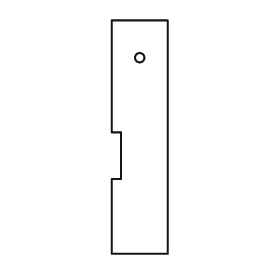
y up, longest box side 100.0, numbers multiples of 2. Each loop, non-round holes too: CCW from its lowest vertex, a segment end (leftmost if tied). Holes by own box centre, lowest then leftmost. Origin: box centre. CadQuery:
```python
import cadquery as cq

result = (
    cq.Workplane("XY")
    .moveTo(-12.0, -50.0)
    .lineTo(12.0, -50.0)
    .lineTo(12.0, 50.0)
    .lineTo(-12.0, 50.0)
    .lineTo(-12.0, 2.0)
    .lineTo(-8.0, 2.0)
    .lineTo(-8.0, -18.0)
    .lineTo(-12.0, -18.0)
    .close()
    .moveTo(0.0, 34.0)
    .circle(2.0)
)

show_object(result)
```